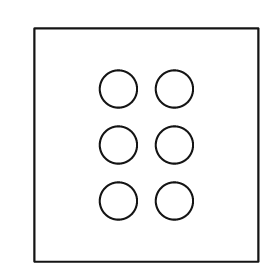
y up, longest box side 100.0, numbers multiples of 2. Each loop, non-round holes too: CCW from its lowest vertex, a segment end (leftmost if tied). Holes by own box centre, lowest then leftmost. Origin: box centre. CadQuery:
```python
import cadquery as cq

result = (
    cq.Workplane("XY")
    .moveTo(-48.0, -50.0)
    .lineTo(48.0, -50.0)
    .lineTo(48.0, 50.0)
    .lineTo(-48.0, 50.0)
    .close()
    .moveTo(-12.0, -24.0)
    .circle(8.0)
    .moveTo(12.0, -24.0)
    .circle(8.0)
    .moveTo(-12.0, 0.0)
    .circle(8.0)
    .moveTo(12.0, 0.0)
    .circle(8.0)
    .moveTo(-12.0, 24.0)
    .circle(8.0)
    .moveTo(12.0, 24.0)
    .circle(8.0)
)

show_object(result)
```